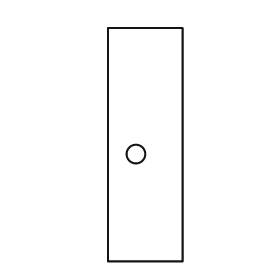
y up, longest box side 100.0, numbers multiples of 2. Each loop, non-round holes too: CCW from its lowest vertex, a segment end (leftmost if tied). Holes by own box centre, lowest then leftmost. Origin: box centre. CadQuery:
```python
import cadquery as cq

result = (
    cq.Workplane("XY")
    .moveTo(-16.0, -50.0)
    .lineTo(16.0, -50.0)
    .lineTo(16.0, 50.0)
    .lineTo(-16.0, 50.0)
    .close()
    .moveTo(-4.0, -4.0)
    .circle(4.0)
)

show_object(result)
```